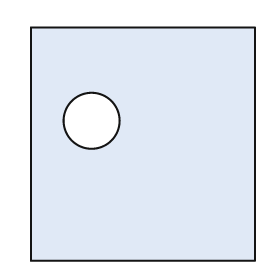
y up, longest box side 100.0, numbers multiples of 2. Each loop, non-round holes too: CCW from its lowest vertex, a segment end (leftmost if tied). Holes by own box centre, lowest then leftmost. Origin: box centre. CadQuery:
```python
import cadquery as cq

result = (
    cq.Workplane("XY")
    .moveTo(-48.0, -50.0)
    .lineTo(48.0, -50.0)
    .lineTo(48.0, 50.0)
    .lineTo(-48.0, 50.0)
    .close()
    .moveTo(-22.0, 10.0)
    .circle(12.0)
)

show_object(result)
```